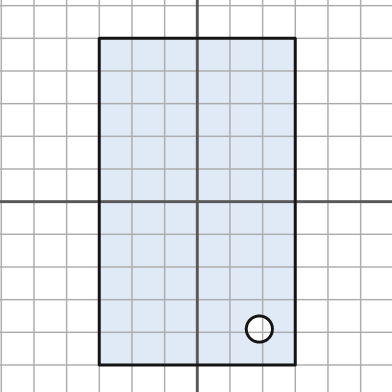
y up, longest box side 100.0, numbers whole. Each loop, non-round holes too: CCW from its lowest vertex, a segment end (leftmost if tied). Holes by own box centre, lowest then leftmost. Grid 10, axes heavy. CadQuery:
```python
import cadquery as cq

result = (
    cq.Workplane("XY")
    .moveTo(-30.0, -50.0)
    .lineTo(30.0, -50.0)
    .lineTo(30.0, 50.0)
    .lineTo(-30.0, 50.0)
    .close()
    .moveTo(19.0, -39.0)
    .circle(4.0)
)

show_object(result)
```